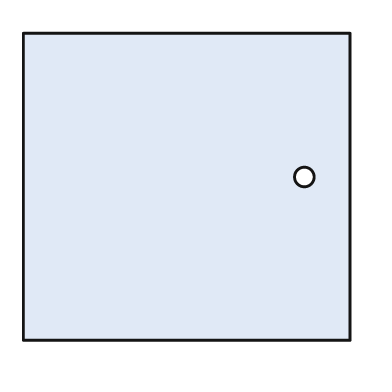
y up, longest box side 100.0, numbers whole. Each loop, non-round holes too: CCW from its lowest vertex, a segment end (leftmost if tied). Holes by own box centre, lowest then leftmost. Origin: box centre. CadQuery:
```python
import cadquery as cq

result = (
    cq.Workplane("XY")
    .moveTo(-50.0, -47.0)
    .lineTo(50.0, -47.0)
    .lineTo(50.0, 47.0)
    .lineTo(-50.0, 47.0)
    .close()
    .moveTo(36.0, 3.0)
    .circle(3.0)
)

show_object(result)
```